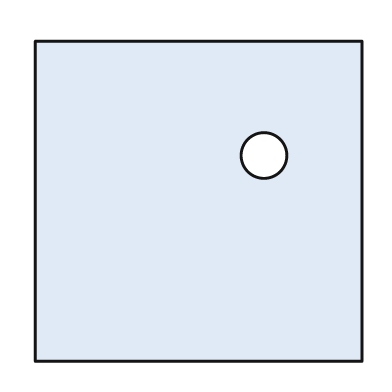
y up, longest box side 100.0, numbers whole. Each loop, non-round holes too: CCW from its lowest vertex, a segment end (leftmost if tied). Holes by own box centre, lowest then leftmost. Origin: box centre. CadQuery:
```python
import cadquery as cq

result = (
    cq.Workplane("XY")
    .moveTo(-50.0, -49.0)
    .lineTo(50.0, -49.0)
    .lineTo(50.0, 49.0)
    .lineTo(-50.0, 49.0)
    .close()
    .moveTo(20.0, 14.0)
    .circle(7.0)
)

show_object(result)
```